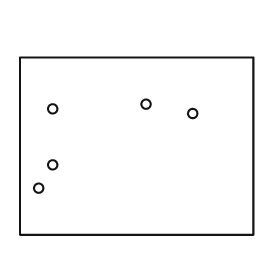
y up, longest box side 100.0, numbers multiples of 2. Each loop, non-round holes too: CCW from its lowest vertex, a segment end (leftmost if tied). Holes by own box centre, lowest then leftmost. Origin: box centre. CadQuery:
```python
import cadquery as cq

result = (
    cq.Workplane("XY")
    .moveTo(-50.0, -38.0)
    .lineTo(50.0, -38.0)
    .lineTo(50.0, 38.0)
    .lineTo(-50.0, 38.0)
    .close()
    .moveTo(-42.0, -18.0)
    .circle(2.0)
    .moveTo(-36.0, -8.0)
    .circle(2.0)
    .moveTo(24.0, 14.0)
    .circle(2.0)
    .moveTo(-36.0, 16.0)
    .circle(2.0)
    .moveTo(4.0, 18.0)
    .circle(2.0)
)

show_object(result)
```